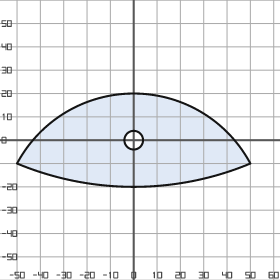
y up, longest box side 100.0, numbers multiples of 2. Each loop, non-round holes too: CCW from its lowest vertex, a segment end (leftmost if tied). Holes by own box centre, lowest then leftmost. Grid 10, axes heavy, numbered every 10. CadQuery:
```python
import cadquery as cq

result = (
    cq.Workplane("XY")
    .moveTo(-50.0, -10.0)
    .threePointArc((0.0, -20.0), (50.0, -10.0))
    .threePointArc((0.0, 20.0), (-50.0, -10.0))
    .close()
    .moveTo(0.0, 0.0)
    .circle(4.0)
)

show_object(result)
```